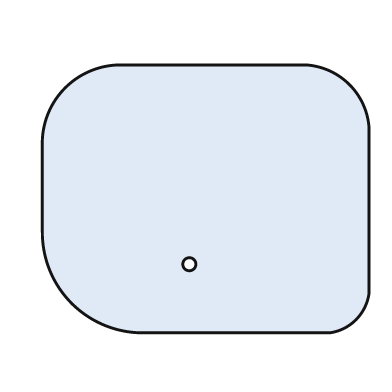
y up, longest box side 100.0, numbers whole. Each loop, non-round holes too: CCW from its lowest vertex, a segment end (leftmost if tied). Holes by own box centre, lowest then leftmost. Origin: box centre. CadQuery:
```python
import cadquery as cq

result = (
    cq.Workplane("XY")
    .moveTo(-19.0, -41.0)
    .lineTo(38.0, -41.0)
    .threePointArc((46.0, -37.0), (50.0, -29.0))
    .lineTo(50.0, 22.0)
    .threePointArc((44.0, 35.0), (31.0, 41.0))
    .lineTo(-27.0, 41.0)
    .threePointArc((-43.0, 34.0), (-50.0, 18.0))
    .lineTo(-50.0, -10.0)
    .threePointArc((-41.0, -32.0), (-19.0, -41.0))
    .close()
    .moveTo(-5.0, -20.0)
    .circle(2.0)
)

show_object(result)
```